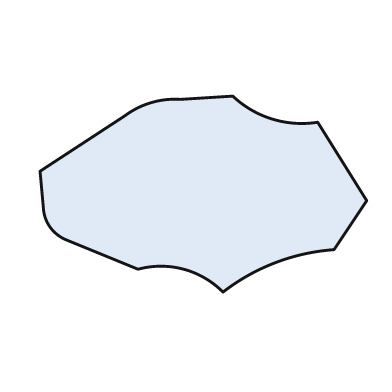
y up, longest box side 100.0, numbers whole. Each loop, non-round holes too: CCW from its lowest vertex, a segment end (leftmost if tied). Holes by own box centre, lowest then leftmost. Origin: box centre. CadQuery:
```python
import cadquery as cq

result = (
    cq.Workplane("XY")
    .moveTo(6.0, -30.0)
    .threePointArc((22.0, -21.0), (40.0, -17.0))
    .lineTo(50.0, -2.0)
    .lineTo(35.0, 22.0)
    .threePointArc((21.0, 23.0), (9.0, 30.0))
    .lineTo(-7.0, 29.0)
    .threePointArc((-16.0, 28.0), (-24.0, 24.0))
    .lineTo(-50.0, 7.0)
    .lineTo(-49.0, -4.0)
    .threePointArc((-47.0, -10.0), (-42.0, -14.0))
    .lineTo(-20.0, -23.0)
    .threePointArc((-6.0, -23.0), (6.0, -30.0))
    .close()
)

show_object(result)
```